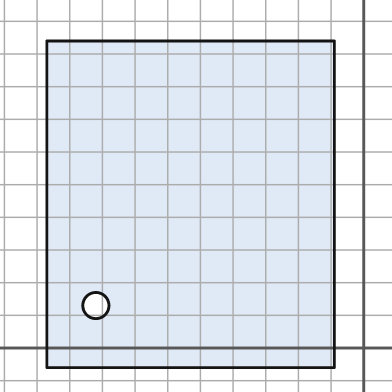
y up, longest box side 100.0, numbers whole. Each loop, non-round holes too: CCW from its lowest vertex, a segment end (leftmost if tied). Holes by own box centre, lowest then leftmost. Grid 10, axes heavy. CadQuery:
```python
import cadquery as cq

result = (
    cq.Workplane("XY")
    .moveTo(-97.0, -6.0)
    .lineTo(-9.0, -6.0)
    .lineTo(-9.0, 94.0)
    .lineTo(-97.0, 94.0)
    .close()
    .moveTo(-82.0, 13.0)
    .circle(4.0)
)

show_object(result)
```